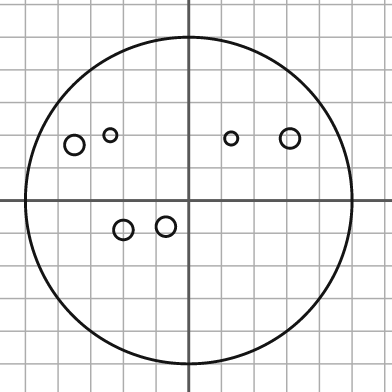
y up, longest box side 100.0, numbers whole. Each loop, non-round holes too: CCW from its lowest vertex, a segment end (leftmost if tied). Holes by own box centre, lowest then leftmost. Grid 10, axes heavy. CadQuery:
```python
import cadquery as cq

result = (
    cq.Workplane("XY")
    .moveTo(0.0, 0.0)
    .circle(50.0)
    .moveTo(-20.0, -9.0)
    .circle(3.0)
    .moveTo(-7.0, -8.0)
    .circle(3.0)
    .moveTo(-35.0, 17.0)
    .circle(3.0)
    .moveTo(13.0, 19.0)
    .circle(2.0)
    .moveTo(31.0, 19.0)
    .circle(3.0)
    .moveTo(-24.0, 20.0)
    .circle(2.0)
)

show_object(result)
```